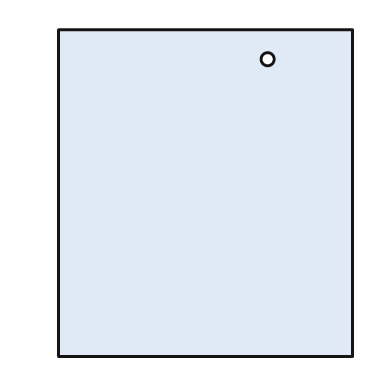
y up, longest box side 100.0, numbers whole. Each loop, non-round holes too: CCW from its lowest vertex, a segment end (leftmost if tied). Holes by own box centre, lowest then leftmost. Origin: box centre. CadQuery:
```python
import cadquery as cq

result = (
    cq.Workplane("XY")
    .moveTo(-45.0, -50.0)
    .lineTo(45.0, -50.0)
    .lineTo(45.0, 50.0)
    .lineTo(-45.0, 50.0)
    .close()
    .moveTo(19.0, 41.0)
    .circle(2.0)
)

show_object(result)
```